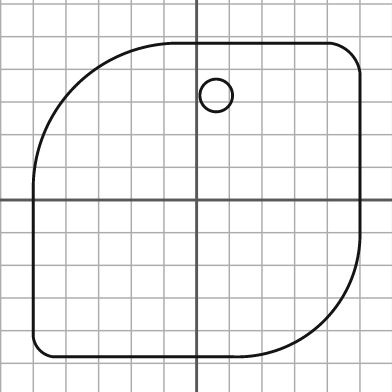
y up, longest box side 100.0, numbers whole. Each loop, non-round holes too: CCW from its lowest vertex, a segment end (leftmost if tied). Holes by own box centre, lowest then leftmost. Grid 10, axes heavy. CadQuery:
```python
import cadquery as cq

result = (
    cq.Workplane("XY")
    .moveTo(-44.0, -48.0)
    .lineTo(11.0, -48.0)
    .threePointArc((39.0, -37.0), (50.0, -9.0))
    .lineTo(50.0, 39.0)
    .threePointArc((47.0, 45.0), (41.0, 48.0))
    .lineTo(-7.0, 48.0)
    .threePointArc((-37.0, 35.0), (-50.0, 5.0))
    .lineTo(-50.0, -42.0)
    .threePointArc((-48.0, -46.0), (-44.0, -48.0))
    .close()
    .moveTo(6.0, 32.0)
    .circle(5.0)
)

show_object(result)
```